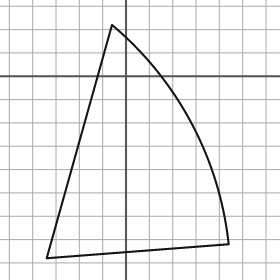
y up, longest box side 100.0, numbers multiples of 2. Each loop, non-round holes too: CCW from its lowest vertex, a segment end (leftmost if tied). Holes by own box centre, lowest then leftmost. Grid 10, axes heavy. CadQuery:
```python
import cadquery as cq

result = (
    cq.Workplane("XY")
    .moveTo(-34.0, -78.0)
    .lineTo(44.0, -72.0)
    .threePointArc((28.0, -20.0), (-6.0, 22.0))
    .close()
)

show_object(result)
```